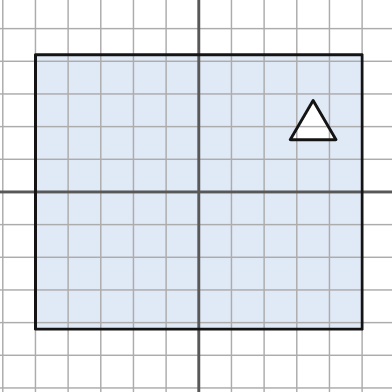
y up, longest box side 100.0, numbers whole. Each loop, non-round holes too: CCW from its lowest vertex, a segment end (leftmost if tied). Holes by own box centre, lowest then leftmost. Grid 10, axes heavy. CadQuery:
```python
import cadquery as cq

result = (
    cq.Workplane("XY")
    .moveTo(-50.0, -42.0)
    .lineTo(50.0, -42.0)
    .lineTo(50.0, 42.0)
    .lineTo(-50.0, 42.0)
    .close()
    .moveTo(28.0, 16.0)
    .lineTo(42.0, 16.0)
    .lineTo(35.0, 28.0)
    .close()
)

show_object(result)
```